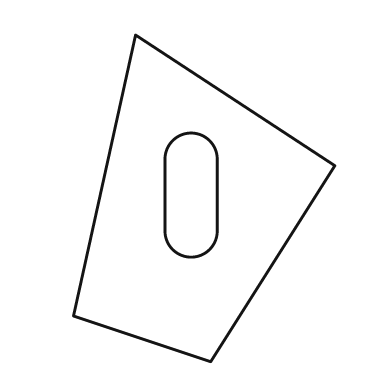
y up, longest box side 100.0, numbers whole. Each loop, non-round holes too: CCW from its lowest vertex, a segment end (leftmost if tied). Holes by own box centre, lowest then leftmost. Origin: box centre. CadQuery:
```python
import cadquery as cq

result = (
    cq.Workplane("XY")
    .moveTo(2.0, -50.0)
    .lineTo(40.0, 10.0)
    .lineTo(-21.0, 50.0)
    .lineTo(-40.0, -36.0)
    .close()
    .moveTo(-12.0, -10.0)
    .threePointArc((-4.0, -18.0), (4.0, -10.0))
    .lineTo(4.0, 12.0)
    .threePointArc((-4.0, 20.0), (-12.0, 12.0))
    .close()
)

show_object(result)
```